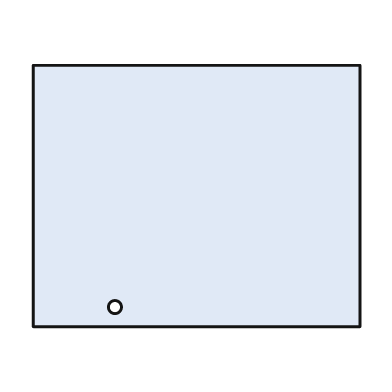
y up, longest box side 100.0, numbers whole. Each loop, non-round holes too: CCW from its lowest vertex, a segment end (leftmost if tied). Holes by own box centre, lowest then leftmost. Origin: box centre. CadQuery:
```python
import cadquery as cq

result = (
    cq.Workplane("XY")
    .moveTo(-50.0, -40.0)
    .lineTo(50.0, -40.0)
    .lineTo(50.0, 40.0)
    .lineTo(-50.0, 40.0)
    .close()
    .moveTo(-25.0, -34.0)
    .circle(2.0)
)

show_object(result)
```